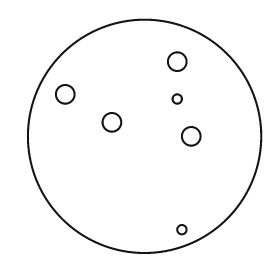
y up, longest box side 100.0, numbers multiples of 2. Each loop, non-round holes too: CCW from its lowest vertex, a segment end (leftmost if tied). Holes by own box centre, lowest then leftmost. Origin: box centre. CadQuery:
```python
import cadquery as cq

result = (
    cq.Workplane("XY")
    .moveTo(0.0, 0.0)
    .circle(50.0)
    .moveTo(16.0, -40.0)
    .circle(2.0)
    .moveTo(20.0, 0.0)
    .circle(4.0)
    .moveTo(-14.0, 6.0)
    .circle(4.0)
    .moveTo(14.0, 16.0)
    .circle(2.0)
    .moveTo(-34.0, 18.0)
    .circle(4.0)
    .moveTo(14.0, 32.0)
    .circle(4.0)
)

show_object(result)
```